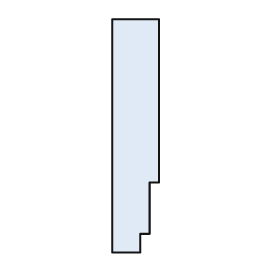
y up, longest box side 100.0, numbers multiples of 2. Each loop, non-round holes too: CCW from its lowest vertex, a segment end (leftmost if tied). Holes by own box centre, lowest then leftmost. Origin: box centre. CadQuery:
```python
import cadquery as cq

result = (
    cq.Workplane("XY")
    .moveTo(-10.0, -50.0)
    .lineTo(2.0, -50.0)
    .lineTo(2.0, -42.0)
    .lineTo(6.0, -42.0)
    .lineTo(6.0, -20.0)
    .lineTo(10.0, -20.0)
    .lineTo(10.0, 50.0)
    .lineTo(-10.0, 50.0)
    .close()
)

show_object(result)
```